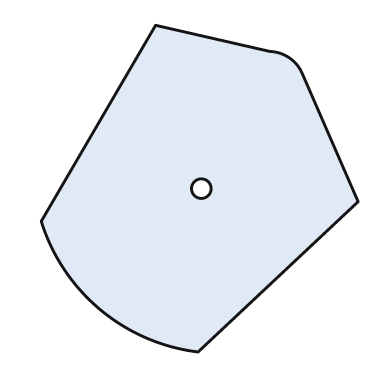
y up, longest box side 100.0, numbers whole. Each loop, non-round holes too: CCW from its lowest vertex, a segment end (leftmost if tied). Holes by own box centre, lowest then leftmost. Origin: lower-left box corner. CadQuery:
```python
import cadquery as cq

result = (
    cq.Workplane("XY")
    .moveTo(48.0, 0.0)
    .lineTo(97.0, 46.0)
    .lineTo(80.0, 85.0)
    .threePointArc((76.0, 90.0), (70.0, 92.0))
    .lineTo(35.0, 100.0)
    .lineTo(0.0, 40.0)
    .threePointArc((18.0, 13.0), (48.0, 0.0))
    .close()
    .moveTo(49.0, 50.0)
    .circle(3.0)
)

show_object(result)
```